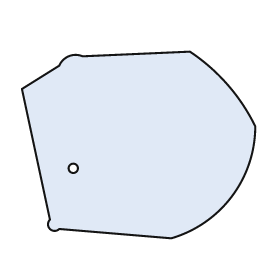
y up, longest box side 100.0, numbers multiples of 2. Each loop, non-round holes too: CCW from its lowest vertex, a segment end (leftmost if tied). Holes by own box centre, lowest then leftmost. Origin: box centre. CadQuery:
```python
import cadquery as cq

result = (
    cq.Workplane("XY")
    .moveTo(14.0, -40.0)
    .threePointArc((40.0, -22.0), (50.0, 8.0))
    .threePointArc((38.0, 26.0), (22.0, 40.0))
    .lineTo(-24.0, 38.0)
    .threePointArc((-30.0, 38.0), (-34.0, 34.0))
    .lineTo(-50.0, 24.0)
    .lineTo(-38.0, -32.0)
    .threePointArc((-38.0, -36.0), (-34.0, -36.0))
    .close()
    .moveTo(-28.0, -10.0)
    .circle(2.0)
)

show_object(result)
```